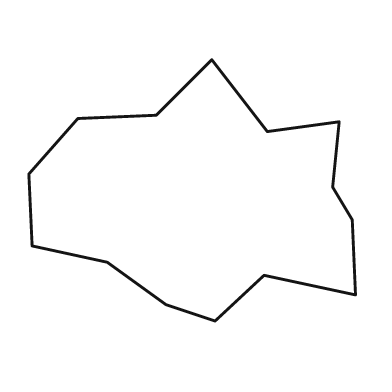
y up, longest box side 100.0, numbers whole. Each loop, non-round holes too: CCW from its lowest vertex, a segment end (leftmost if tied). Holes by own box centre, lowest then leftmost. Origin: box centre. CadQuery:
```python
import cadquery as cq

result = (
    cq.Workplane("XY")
    .moveTo(7.0, -40.0)
    .lineTo(22.0, -26.0)
    .lineTo(50.0, -32.0)
    .lineTo(49.0, -9.0)
    .lineTo(43.0, 1.0)
    .lineTo(45.0, 21.0)
    .lineTo(23.0, 18.0)
    .lineTo(6.0, 40.0)
    .lineTo(-11.0, 23.0)
    .lineTo(-35.0, 22.0)
    .lineTo(-50.0, 5.0)
    .lineTo(-49.0, -17.0)
    .lineTo(-26.0, -22.0)
    .lineTo(-8.0, -35.0)
    .close()
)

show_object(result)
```